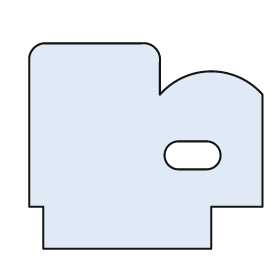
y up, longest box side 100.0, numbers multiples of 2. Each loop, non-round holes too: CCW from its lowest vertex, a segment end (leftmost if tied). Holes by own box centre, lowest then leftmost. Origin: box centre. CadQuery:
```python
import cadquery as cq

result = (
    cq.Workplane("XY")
    .moveTo(-44.0, -44.0)
    .lineTo(28.0, -44.0)
    .lineTo(28.0, -26.0)
    .lineTo(50.0, -26.0)
    .lineTo(50.0, 22.0)
    .threePointArc((28.0, 32.0), (6.0, 22.0))
    .lineTo(6.0, 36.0)
    .threePointArc((4.0, 42.0), (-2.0, 44.0))
    .lineTo(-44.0, 44.0)
    .threePointArc((-48.0, 42.0), (-50.0, 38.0))
    .lineTo(-50.0, -26.0)
    .lineTo(-44.0, -26.0)
    .close()
    .moveTo(14.0, -10.0)
    .lineTo(26.0, -10.0)
    .threePointArc((32.0, -4.0), (26.0, 2.0))
    .lineTo(14.0, 2.0)
    .threePointArc((8.0, -4.0), (14.0, -10.0))
    .close()
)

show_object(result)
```